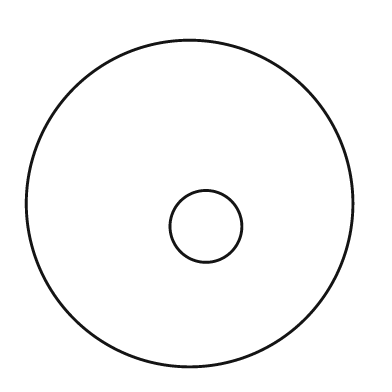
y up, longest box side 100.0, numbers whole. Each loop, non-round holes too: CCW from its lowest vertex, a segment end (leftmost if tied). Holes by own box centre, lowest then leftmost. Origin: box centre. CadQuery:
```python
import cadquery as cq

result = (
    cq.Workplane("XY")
    .moveTo(0.0, 0.0)
    .circle(50.0)
    .moveTo(5.0, -7.0)
    .circle(11.0)
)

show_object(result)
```